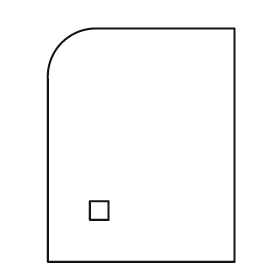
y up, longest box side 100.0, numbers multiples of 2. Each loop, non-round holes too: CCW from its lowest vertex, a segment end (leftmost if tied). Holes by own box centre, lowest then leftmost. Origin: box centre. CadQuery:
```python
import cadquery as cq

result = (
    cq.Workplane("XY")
    .moveTo(-40.0, -50.0)
    .lineTo(40.0, -50.0)
    .lineTo(40.0, 50.0)
    .lineTo(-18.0, 50.0)
    .threePointArc((-34.0, 44.0), (-40.0, 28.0))
    .close()
    .moveTo(-22.0, -32.0)
    .lineTo(-14.0, -32.0)
    .lineTo(-14.0, -24.0)
    .lineTo(-22.0, -24.0)
    .close()
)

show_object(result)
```